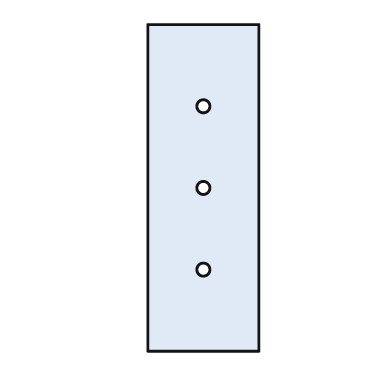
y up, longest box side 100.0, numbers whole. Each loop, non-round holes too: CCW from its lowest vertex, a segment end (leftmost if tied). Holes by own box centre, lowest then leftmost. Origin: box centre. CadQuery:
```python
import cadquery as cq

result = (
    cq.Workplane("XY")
    .moveTo(-17.0, -50.0)
    .lineTo(17.0, -50.0)
    .lineTo(17.0, 50.0)
    .lineTo(-17.0, 50.0)
    .close()
    .moveTo(0.0, -25.0)
    .circle(2.0)
    .moveTo(0.0, 0.0)
    .circle(2.0)
    .moveTo(0.0, 25.0)
    .circle(2.0)
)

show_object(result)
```